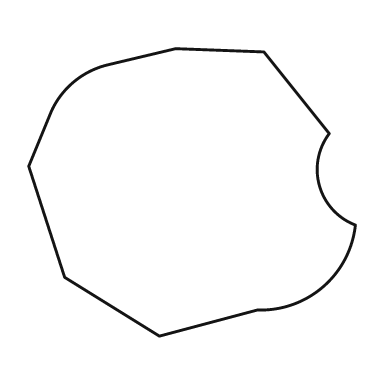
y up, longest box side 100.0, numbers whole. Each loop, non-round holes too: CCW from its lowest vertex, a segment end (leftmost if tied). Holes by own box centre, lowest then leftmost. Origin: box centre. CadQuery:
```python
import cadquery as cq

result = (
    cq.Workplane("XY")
    .moveTo(-10.0, -44.0)
    .lineTo(20.0, -36.0)
    .threePointArc((40.0, -29.0), (50.0, -10.0))
    .threePointArc((39.0, 2.0), (42.0, 18.0))
    .lineTo(22.0, 43.0)
    .lineTo(-5.0, 44.0)
    .lineTo(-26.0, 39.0)
    .threePointArc((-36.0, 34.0), (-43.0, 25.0))
    .lineTo(-50.0, 8.0)
    .lineTo(-39.0, -26.0)
    .close()
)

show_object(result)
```